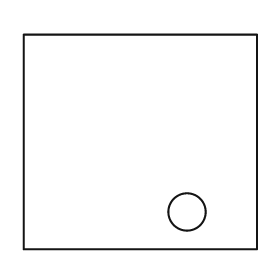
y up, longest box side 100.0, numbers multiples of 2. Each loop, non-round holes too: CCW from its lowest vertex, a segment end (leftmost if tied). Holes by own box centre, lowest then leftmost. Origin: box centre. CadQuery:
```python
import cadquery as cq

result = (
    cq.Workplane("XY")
    .moveTo(-50.0, -46.0)
    .lineTo(50.0, -46.0)
    .lineTo(50.0, 46.0)
    .lineTo(-50.0, 46.0)
    .close()
    .moveTo(20.0, -30.0)
    .circle(8.0)
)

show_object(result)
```